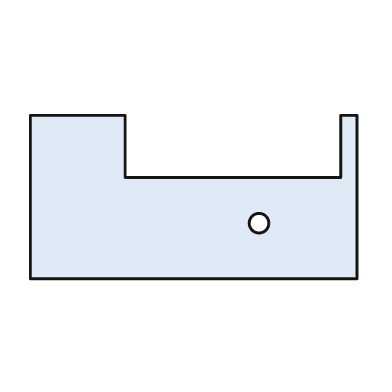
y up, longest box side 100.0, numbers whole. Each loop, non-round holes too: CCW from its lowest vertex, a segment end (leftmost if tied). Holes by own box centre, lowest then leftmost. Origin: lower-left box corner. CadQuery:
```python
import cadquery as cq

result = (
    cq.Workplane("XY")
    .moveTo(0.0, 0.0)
    .lineTo(100.0, 0.0)
    .lineTo(100.0, 50.0)
    .lineTo(95.0, 50.0)
    .lineTo(95.0, 31.0)
    .lineTo(29.0, 31.0)
    .lineTo(29.0, 50.0)
    .lineTo(0.0, 50.0)
    .close()
    .moveTo(70.0, 17.0)
    .circle(3.0)
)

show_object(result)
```